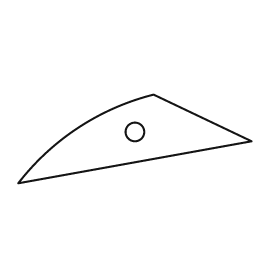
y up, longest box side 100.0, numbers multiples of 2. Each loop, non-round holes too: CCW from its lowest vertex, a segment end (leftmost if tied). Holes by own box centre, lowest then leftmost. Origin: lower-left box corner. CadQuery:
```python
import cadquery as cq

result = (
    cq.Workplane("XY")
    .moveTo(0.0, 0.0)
    .lineTo(100.0, 18.0)
    .lineTo(58.0, 38.0)
    .threePointArc((26.0, 24.0), (0.0, 0.0))
    .close()
    .moveTo(50.0, 22.0)
    .circle(4.0)
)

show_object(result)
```